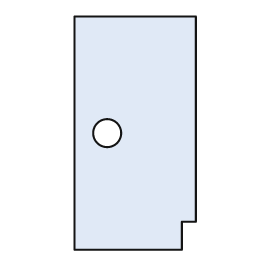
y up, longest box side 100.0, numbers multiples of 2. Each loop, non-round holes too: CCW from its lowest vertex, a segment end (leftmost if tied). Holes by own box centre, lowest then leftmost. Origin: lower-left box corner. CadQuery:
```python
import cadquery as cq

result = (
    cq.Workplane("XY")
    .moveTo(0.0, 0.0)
    .lineTo(46.0, 0.0)
    .lineTo(46.0, 12.0)
    .lineTo(52.0, 12.0)
    .lineTo(52.0, 100.0)
    .lineTo(0.0, 100.0)
    .close()
    .moveTo(14.0, 50.0)
    .circle(6.0)
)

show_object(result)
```